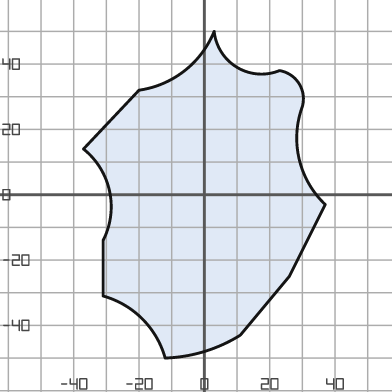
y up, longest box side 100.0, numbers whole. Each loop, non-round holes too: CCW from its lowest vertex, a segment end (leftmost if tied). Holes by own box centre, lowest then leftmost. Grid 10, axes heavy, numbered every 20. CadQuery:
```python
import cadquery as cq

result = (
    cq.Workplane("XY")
    .moveTo(-12.0, -50.0)
    .threePointArc((0.0, -48.0), (11.0, -43.0))
    .lineTo(26.0, -25.0)
    .lineTo(37.0, -3.0)
    .threePointArc((29.0, 11.0), (30.0, 27.0))
    .threePointArc((29.0, 34.0), (23.0, 38.0))
    .threePointArc((10.0, 39.0), (3.0, 50.0))
    .threePointArc((-6.0, 38.0), (-20.0, 32.0))
    .lineTo(-37.0, 14.0)
    .threePointArc((-29.0, 1.0), (-31.0, -14.0))
    .lineTo(-31.0, -31.0)
    .threePointArc((-19.0, -38.0), (-12.0, -50.0))
    .close()
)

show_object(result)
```